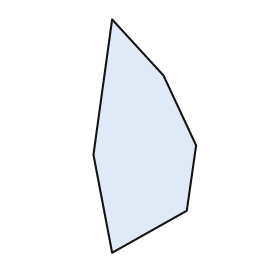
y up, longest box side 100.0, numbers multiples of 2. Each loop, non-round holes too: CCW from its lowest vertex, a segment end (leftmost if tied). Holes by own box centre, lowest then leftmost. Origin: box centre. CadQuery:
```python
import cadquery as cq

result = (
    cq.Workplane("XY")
    .moveTo(-14.0, -50.0)
    .lineTo(18.0, -32.0)
    .lineTo(22.0, -4.0)
    .lineTo(8.0, 26.0)
    .lineTo(-14.0, 50.0)
    .lineTo(-22.0, -8.0)
    .close()
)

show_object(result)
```